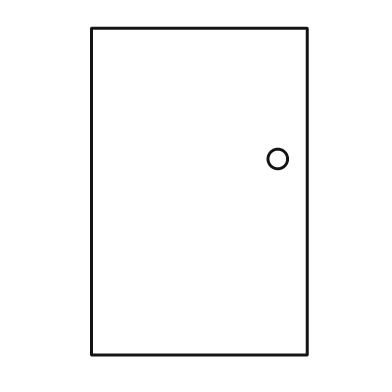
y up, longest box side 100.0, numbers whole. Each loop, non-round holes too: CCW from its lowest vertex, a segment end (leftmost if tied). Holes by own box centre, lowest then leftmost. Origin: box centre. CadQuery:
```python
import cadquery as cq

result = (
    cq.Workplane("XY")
    .moveTo(-33.0, -50.0)
    .lineTo(33.0, -50.0)
    .lineTo(33.0, 50.0)
    .lineTo(-33.0, 50.0)
    .close()
    .moveTo(24.0, 10.0)
    .circle(3.0)
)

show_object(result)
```